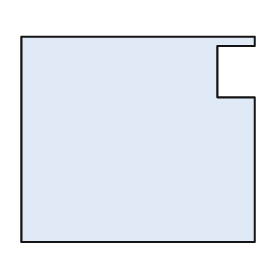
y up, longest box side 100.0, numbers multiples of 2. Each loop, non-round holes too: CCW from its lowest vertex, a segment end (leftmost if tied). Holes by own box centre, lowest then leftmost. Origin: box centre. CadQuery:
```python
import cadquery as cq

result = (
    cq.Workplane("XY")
    .moveTo(-50.0, -44.0)
    .lineTo(50.0, -44.0)
    .lineTo(50.0, 18.0)
    .lineTo(34.0, 18.0)
    .lineTo(34.0, 40.0)
    .lineTo(50.0, 40.0)
    .lineTo(50.0, 44.0)
    .lineTo(-50.0, 44.0)
    .close()
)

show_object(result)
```